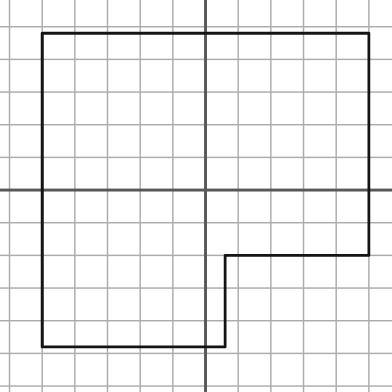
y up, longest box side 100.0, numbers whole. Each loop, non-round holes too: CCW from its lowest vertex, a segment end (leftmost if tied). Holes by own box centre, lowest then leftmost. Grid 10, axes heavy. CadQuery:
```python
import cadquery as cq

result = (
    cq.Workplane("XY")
    .moveTo(-50.0, -48.0)
    .lineTo(6.0, -48.0)
    .lineTo(6.0, -20.0)
    .lineTo(50.0, -20.0)
    .lineTo(50.0, 48.0)
    .lineTo(-50.0, 48.0)
    .close()
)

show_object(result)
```